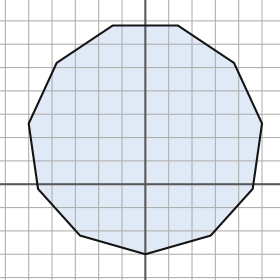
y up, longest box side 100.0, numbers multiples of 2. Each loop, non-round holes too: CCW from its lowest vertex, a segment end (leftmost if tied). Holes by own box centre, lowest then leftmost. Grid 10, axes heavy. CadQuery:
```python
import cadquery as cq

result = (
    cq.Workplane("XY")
    .moveTo(0.0, -30.0)
    .lineTo(28.0, -22.0)
    .lineTo(46.0, -2.0)
    .lineTo(50.0, 26.0)
    .lineTo(38.0, 52.0)
    .lineTo(14.0, 68.0)
    .lineTo(-14.0, 68.0)
    .lineTo(-38.0, 52.0)
    .lineTo(-50.0, 26.0)
    .lineTo(-46.0, -2.0)
    .lineTo(-28.0, -22.0)
    .close()
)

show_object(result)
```